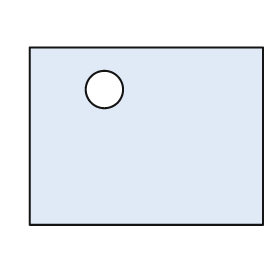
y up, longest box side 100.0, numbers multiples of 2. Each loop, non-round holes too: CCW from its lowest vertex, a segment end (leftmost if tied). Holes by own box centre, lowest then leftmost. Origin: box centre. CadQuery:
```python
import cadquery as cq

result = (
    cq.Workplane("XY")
    .moveTo(-50.0, -38.0)
    .lineTo(50.0, -38.0)
    .lineTo(50.0, 38.0)
    .lineTo(-50.0, 38.0)
    .close()
    .moveTo(-18.0, 20.0)
    .circle(8.0)
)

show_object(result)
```